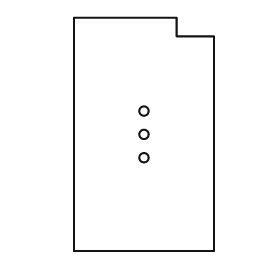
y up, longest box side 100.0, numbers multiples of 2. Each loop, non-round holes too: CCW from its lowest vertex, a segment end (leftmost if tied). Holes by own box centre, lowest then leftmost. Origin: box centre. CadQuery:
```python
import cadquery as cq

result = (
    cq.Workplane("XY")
    .moveTo(-30.0, -50.0)
    .lineTo(30.0, -50.0)
    .lineTo(30.0, 42.0)
    .lineTo(14.0, 42.0)
    .lineTo(14.0, 50.0)
    .lineTo(-30.0, 50.0)
    .close()
    .moveTo(0.0, -10.0)
    .circle(2.0)
    .moveTo(0.0, 0.0)
    .circle(2.0)
    .moveTo(0.0, 10.0)
    .circle(2.0)
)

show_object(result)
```